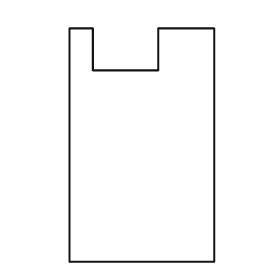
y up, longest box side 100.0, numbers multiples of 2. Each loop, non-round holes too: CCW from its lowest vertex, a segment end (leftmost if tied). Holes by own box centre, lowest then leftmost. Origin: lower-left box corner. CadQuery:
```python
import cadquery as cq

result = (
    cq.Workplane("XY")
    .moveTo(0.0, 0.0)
    .lineTo(62.0, 0.0)
    .lineTo(62.0, 100.0)
    .lineTo(38.0, 100.0)
    .lineTo(38.0, 82.0)
    .lineTo(10.0, 82.0)
    .lineTo(10.0, 100.0)
    .lineTo(0.0, 100.0)
    .close()
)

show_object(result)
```